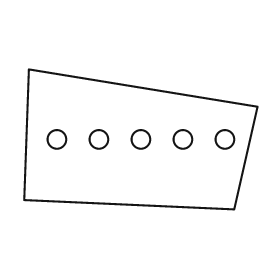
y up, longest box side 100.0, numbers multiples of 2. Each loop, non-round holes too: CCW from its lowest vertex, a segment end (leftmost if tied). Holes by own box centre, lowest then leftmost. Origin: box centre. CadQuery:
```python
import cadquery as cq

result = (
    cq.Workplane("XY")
    .moveTo(40.0, -30.0)
    .lineTo(50.0, 14.0)
    .lineTo(-48.0, 30.0)
    .lineTo(-50.0, -26.0)
    .close()
    .moveTo(-36.0, 0.0)
    .circle(4.0)
    .moveTo(-18.0, 0.0)
    .circle(4.0)
    .moveTo(0.0, 0.0)
    .circle(4.0)
    .moveTo(18.0, 0.0)
    .circle(4.0)
    .moveTo(36.0, 0.0)
    .circle(4.0)
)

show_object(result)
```